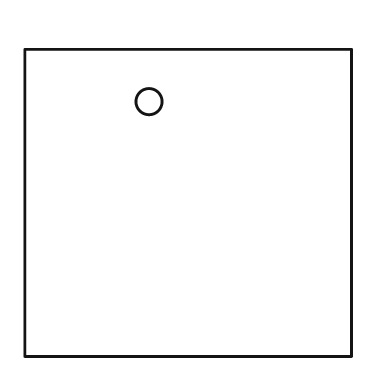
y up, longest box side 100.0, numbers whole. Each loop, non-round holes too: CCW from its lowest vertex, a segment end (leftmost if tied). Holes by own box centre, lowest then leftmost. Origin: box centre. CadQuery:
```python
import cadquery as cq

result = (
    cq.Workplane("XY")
    .moveTo(-50.0, -47.0)
    .lineTo(50.0, -47.0)
    .lineTo(50.0, 47.0)
    .lineTo(-50.0, 47.0)
    .close()
    .moveTo(-12.0, 31.0)
    .circle(4.0)
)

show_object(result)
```